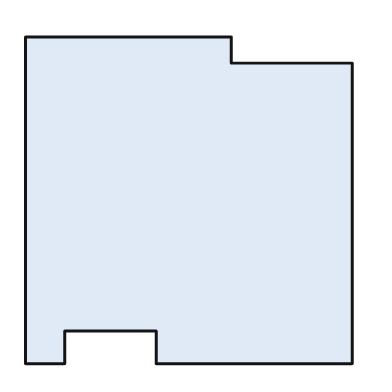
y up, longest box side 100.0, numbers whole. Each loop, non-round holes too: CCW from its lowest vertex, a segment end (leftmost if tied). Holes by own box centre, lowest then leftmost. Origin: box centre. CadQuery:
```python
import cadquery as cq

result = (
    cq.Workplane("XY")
    .moveTo(-50.0, -50.0)
    .lineTo(-38.0, -50.0)
    .lineTo(-38.0, -40.0)
    .lineTo(-10.0, -40.0)
    .lineTo(-10.0, -50.0)
    .lineTo(50.0, -50.0)
    .lineTo(50.0, 42.0)
    .lineTo(13.0, 42.0)
    .lineTo(13.0, 50.0)
    .lineTo(-50.0, 50.0)
    .close()
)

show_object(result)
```